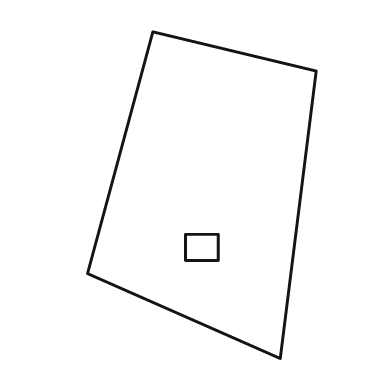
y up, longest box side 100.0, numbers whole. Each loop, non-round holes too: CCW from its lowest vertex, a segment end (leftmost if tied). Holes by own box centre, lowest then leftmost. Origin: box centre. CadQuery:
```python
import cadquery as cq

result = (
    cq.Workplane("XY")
    .moveTo(24.0, -50.0)
    .lineTo(35.0, 38.0)
    .lineTo(-15.0, 50.0)
    .lineTo(-35.0, -24.0)
    .close()
    .moveTo(-5.0, -20.0)
    .lineTo(5.0, -20.0)
    .lineTo(5.0, -12.0)
    .lineTo(-5.0, -12.0)
    .close()
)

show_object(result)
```